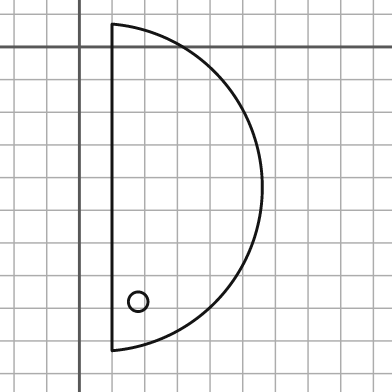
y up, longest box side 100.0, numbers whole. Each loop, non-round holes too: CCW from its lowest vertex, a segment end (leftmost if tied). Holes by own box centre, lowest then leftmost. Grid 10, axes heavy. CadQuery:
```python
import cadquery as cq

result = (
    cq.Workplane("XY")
    .moveTo(10.0, -93.0)
    .threePointArc((56.0, -43.0), (10.0, 7.0))
    .close()
    .moveTo(18.0, -78.0)
    .circle(3.0)
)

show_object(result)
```